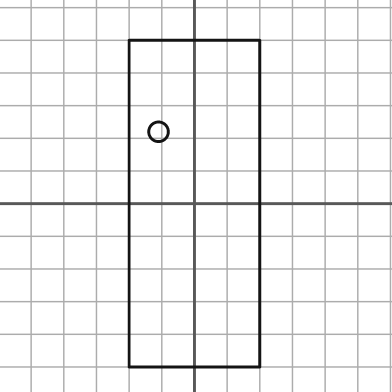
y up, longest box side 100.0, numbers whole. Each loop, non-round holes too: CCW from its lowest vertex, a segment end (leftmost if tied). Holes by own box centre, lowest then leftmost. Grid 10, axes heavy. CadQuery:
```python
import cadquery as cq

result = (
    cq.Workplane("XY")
    .moveTo(-20.0, -50.0)
    .lineTo(20.0, -50.0)
    .lineTo(20.0, 50.0)
    .lineTo(-20.0, 50.0)
    .close()
    .moveTo(-11.0, 22.0)
    .circle(3.0)
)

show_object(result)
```